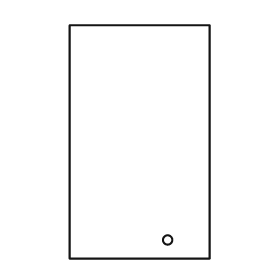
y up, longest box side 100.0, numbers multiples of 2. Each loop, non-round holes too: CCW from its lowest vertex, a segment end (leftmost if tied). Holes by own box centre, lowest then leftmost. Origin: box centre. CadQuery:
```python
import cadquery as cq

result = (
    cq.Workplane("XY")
    .moveTo(-30.0, -50.0)
    .lineTo(30.0, -50.0)
    .lineTo(30.0, 50.0)
    .lineTo(-30.0, 50.0)
    .close()
    .moveTo(12.0, -42.0)
    .circle(2.0)
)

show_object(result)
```